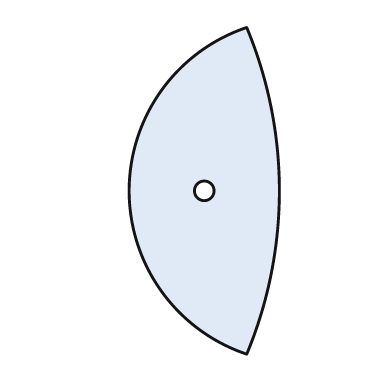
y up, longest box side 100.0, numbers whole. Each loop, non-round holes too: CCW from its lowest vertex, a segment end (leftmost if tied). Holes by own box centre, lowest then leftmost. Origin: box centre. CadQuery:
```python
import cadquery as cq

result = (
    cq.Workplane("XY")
    .moveTo(13.0, -50.0)
    .threePointArc((23.0, 0.0), (13.0, 50.0))
    .threePointArc((-23.0, 0.0), (13.0, -50.0))
    .close()
    .moveTo(0.0, 0.0)
    .circle(3.0)
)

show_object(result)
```